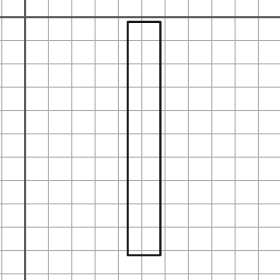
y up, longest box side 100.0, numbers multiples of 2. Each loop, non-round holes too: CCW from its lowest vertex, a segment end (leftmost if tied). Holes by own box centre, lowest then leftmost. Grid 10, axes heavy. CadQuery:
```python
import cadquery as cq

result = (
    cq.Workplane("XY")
    .moveTo(44.0, -102.0)
    .lineTo(58.0, -102.0)
    .lineTo(58.0, -2.0)
    .lineTo(44.0, -2.0)
    .close()
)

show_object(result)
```